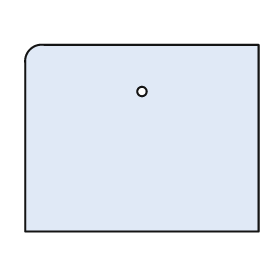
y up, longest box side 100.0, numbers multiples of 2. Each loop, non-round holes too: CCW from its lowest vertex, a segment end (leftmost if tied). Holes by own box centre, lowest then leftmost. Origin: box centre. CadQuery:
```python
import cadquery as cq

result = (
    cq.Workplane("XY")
    .moveTo(-50.0, -40.0)
    .lineTo(50.0, -40.0)
    .lineTo(50.0, 40.0)
    .lineTo(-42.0, 40.0)
    .threePointArc((-48.0, 38.0), (-50.0, 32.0))
    .close()
    .moveTo(0.0, 20.0)
    .circle(2.0)
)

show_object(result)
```